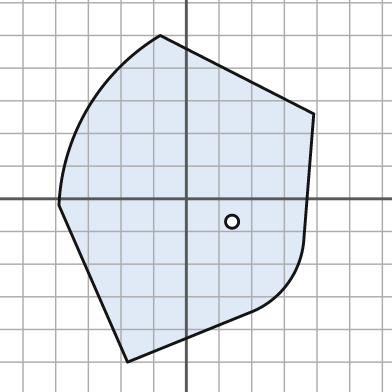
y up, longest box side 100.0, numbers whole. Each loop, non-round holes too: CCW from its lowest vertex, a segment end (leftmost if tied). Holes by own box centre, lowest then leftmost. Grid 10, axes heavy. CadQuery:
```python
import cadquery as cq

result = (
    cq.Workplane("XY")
    .moveTo(-18.0, -50.0)
    .lineTo(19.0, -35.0)
    .threePointArc((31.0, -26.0), (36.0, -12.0))
    .lineTo(39.0, 26.0)
    .lineTo(-8.0, 50.0)
    .threePointArc((-30.0, 28.0), (-39.0, -2.0))
    .close()
    .moveTo(14.0, -7.0)
    .circle(2.0)
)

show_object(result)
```